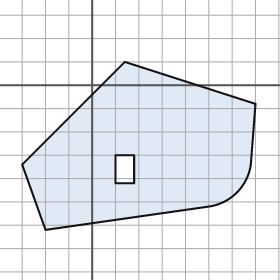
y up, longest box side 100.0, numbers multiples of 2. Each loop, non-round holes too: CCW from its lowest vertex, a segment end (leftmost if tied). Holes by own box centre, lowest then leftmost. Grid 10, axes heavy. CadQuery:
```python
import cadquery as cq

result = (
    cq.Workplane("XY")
    .moveTo(-20.0, -62.0)
    .lineTo(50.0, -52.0)
    .threePointArc((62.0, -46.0), (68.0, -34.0))
    .lineTo(70.0, -8.0)
    .lineTo(14.0, 10.0)
    .lineTo(-30.0, -34.0)
    .close()
    .moveTo(10.0, -42.0)
    .lineTo(18.0, -42.0)
    .lineTo(18.0, -30.0)
    .lineTo(10.0, -30.0)
    .close()
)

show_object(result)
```